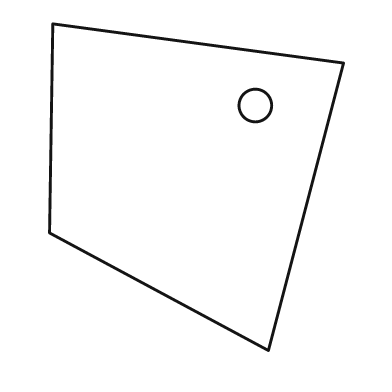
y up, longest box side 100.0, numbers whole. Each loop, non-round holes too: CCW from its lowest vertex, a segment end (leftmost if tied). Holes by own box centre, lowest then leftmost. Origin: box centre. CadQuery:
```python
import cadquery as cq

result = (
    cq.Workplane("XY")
    .moveTo(22.0, -50.0)
    .lineTo(45.0, 38.0)
    .lineTo(-44.0, 50.0)
    .lineTo(-45.0, -14.0)
    .close()
    .moveTo(18.0, 25.0)
    .circle(5.0)
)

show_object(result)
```